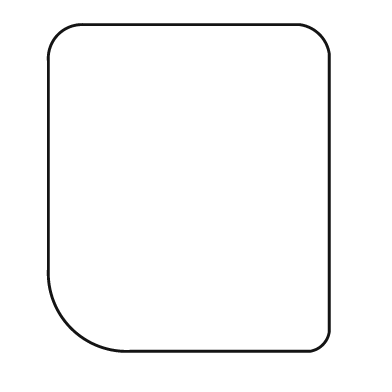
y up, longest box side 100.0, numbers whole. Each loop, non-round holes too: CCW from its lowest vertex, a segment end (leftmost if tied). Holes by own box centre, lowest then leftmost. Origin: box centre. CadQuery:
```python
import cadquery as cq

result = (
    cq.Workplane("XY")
    .moveTo(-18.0, -50.0)
    .lineTo(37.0, -50.0)
    .threePointArc((41.0, -48.0), (43.0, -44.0))
    .lineTo(43.0, 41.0)
    .threePointArc((40.0, 47.0), (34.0, 50.0))
    .lineTo(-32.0, 50.0)
    .threePointArc((-40.0, 47.0), (-43.0, 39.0))
    .lineTo(-43.0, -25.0)
    .threePointArc((-36.0, -43.0), (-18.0, -50.0))
    .close()
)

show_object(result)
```